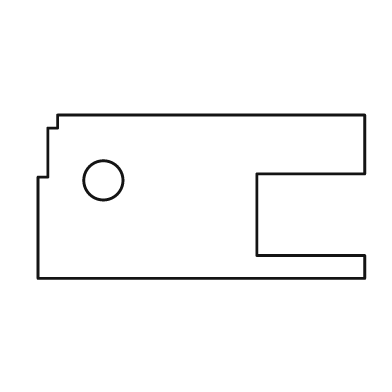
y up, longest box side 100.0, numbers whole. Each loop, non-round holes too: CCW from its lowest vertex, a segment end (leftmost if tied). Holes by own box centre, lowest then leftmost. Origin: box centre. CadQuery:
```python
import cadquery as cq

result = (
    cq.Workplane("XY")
    .moveTo(-50.0, -25.0)
    .lineTo(50.0, -25.0)
    .lineTo(50.0, -18.0)
    .lineTo(17.0, -18.0)
    .lineTo(17.0, 7.0)
    .lineTo(50.0, 7.0)
    .lineTo(50.0, 25.0)
    .lineTo(-44.0, 25.0)
    .lineTo(-44.0, 21.0)
    .lineTo(-47.0, 21.0)
    .lineTo(-47.0, 6.0)
    .lineTo(-50.0, 6.0)
    .close()
    .moveTo(-30.0, 5.0)
    .circle(6.0)
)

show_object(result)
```